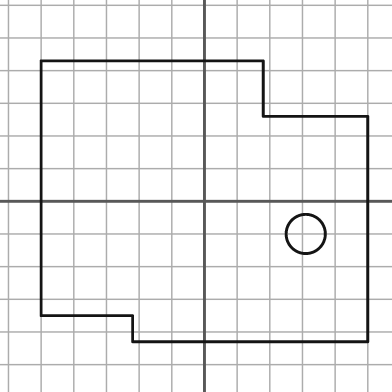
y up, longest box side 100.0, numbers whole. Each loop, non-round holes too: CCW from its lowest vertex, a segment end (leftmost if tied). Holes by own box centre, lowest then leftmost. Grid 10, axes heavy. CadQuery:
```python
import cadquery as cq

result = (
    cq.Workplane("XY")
    .moveTo(-22.0, -43.0)
    .lineTo(50.0, -43.0)
    .lineTo(50.0, 26.0)
    .lineTo(18.0, 26.0)
    .lineTo(18.0, 43.0)
    .lineTo(-50.0, 43.0)
    .lineTo(-50.0, -35.0)
    .lineTo(-22.0, -35.0)
    .close()
    .moveTo(31.0, -10.0)
    .circle(6.0)
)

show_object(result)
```